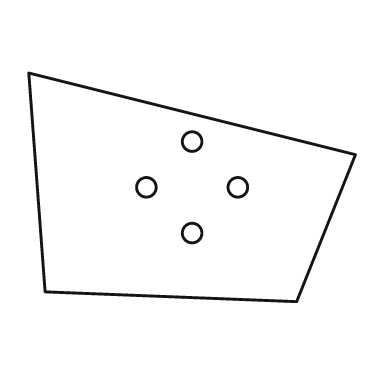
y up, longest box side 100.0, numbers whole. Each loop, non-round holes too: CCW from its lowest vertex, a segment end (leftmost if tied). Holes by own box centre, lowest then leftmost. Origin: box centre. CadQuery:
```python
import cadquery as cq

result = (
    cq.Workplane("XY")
    .moveTo(32.0, -35.0)
    .lineTo(50.0, 10.0)
    .lineTo(-50.0, 35.0)
    .lineTo(-45.0, -32.0)
    .close()
    .moveTo(0.0, -14.0)
    .circle(3.0)
    .moveTo(-14.0, 0.0)
    .circle(3.0)
    .moveTo(14.0, 0.0)
    .circle(3.0)
    .moveTo(0.0, 14.0)
    .circle(3.0)
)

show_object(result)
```